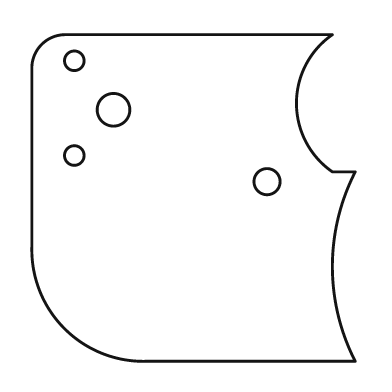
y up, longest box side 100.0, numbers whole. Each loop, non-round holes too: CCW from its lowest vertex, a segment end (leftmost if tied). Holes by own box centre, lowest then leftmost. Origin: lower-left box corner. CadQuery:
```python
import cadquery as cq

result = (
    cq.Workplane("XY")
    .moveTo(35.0, 0.0)
    .lineTo(99.0, 0.0)
    .threePointArc((92.0, 29.0), (99.0, 58.0))
    .lineTo(92.0, 58.0)
    .threePointArc((81.0, 79.0), (92.0, 100.0))
    .lineTo(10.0, 100.0)
    .threePointArc((3.0, 97.0), (0.0, 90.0))
    .lineTo(0.0, 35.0)
    .threePointArc((10.0, 10.0), (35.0, 0.0))
    .close()
    .moveTo(72.0, 55.0)
    .circle(4.0)
    .moveTo(13.0, 63.0)
    .circle(3.0)
    .moveTo(25.0, 77.0)
    .circle(5.0)
    .moveTo(13.0, 92.0)
    .circle(3.0)
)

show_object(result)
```